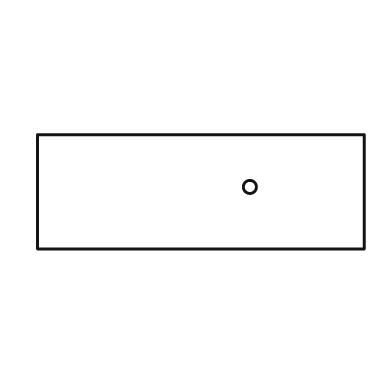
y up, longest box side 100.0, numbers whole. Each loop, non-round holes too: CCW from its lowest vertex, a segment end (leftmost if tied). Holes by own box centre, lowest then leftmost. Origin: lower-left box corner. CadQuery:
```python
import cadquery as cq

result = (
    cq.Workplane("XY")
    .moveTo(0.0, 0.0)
    .lineTo(100.0, 0.0)
    .lineTo(100.0, 35.0)
    .lineTo(0.0, 35.0)
    .close()
    .moveTo(65.0, 19.0)
    .circle(2.0)
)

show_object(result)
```